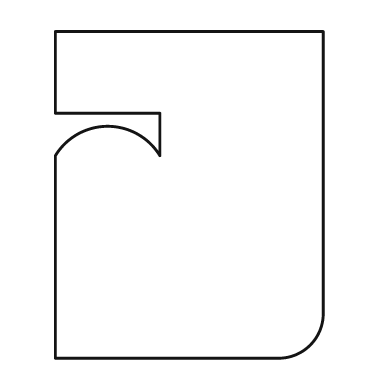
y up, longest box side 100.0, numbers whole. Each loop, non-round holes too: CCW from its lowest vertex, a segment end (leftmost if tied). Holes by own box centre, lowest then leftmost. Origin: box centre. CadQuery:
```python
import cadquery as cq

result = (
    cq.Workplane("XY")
    .moveTo(-41.0, -50.0)
    .lineTo(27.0, -50.0)
    .threePointArc((37.0, -46.0), (41.0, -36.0))
    .lineTo(41.0, 50.0)
    .lineTo(-41.0, 50.0)
    .lineTo(-41.0, 25.0)
    .lineTo(-9.0, 25.0)
    .lineTo(-9.0, 12.0)
    .threePointArc((-25.0, 21.0), (-41.0, 12.0))
    .close()
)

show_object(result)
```